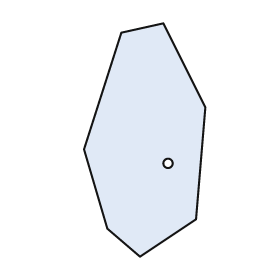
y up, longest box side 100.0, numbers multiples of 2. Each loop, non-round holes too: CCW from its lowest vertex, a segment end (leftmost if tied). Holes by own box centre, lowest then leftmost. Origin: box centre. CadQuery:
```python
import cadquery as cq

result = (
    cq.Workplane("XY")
    .moveTo(-2.0, -50.0)
    .lineTo(22.0, -34.0)
    .lineTo(26.0, 14.0)
    .lineTo(8.0, 50.0)
    .lineTo(-10.0, 46.0)
    .lineTo(-26.0, -4.0)
    .lineTo(-16.0, -38.0)
    .close()
    .moveTo(10.0, -10.0)
    .circle(2.0)
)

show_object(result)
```